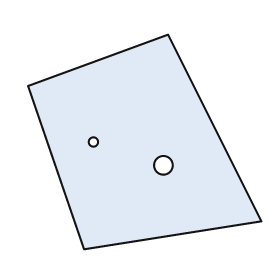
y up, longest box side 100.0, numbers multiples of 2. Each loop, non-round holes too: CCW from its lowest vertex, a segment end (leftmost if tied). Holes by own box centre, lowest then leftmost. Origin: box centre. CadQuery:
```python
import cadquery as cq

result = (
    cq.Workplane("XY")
    .moveTo(-26.0, -46.0)
    .lineTo(50.0, -34.0)
    .lineTo(10.0, 46.0)
    .lineTo(-50.0, 24.0)
    .close()
    .moveTo(8.0, -10.0)
    .circle(4.0)
    .moveTo(-22.0, 0.0)
    .circle(2.0)
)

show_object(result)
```